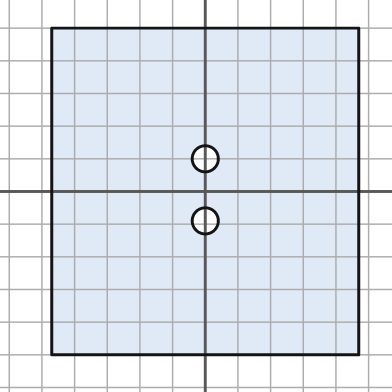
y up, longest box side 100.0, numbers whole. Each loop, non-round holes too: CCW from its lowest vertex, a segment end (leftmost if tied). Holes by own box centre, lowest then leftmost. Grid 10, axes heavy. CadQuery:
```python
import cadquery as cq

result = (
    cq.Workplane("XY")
    .moveTo(-47.0, -50.0)
    .lineTo(47.0, -50.0)
    .lineTo(47.0, 50.0)
    .lineTo(-47.0, 50.0)
    .close()
    .moveTo(0.0, -9.0)
    .circle(4.0)
    .moveTo(0.0, 10.0)
    .circle(4.0)
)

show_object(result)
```